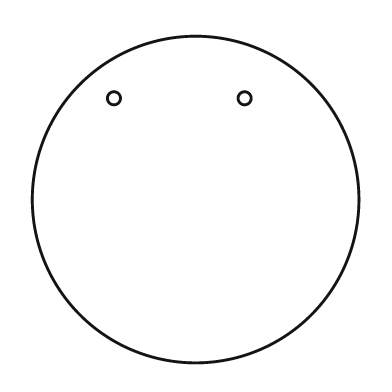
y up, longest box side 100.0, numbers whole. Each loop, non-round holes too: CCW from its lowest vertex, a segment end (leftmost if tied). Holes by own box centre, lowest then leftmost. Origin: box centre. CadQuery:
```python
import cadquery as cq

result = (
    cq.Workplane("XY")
    .moveTo(0.0, 0.0)
    .circle(50.0)
    .moveTo(-25.0, 31.0)
    .circle(2.0)
    .moveTo(15.0, 31.0)
    .circle(2.0)
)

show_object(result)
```